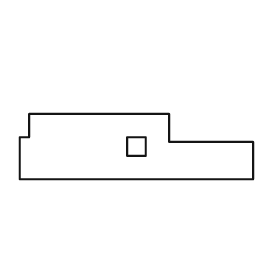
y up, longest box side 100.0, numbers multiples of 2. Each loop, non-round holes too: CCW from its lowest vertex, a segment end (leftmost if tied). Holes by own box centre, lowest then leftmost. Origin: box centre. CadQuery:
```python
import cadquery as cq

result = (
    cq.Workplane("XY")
    .moveTo(-50.0, -14.0)
    .lineTo(50.0, -14.0)
    .lineTo(50.0, 2.0)
    .lineTo(14.0, 2.0)
    .lineTo(14.0, 14.0)
    .lineTo(-46.0, 14.0)
    .lineTo(-46.0, 4.0)
    .lineTo(-50.0, 4.0)
    .close()
    .moveTo(-4.0, -4.0)
    .lineTo(4.0, -4.0)
    .lineTo(4.0, 4.0)
    .lineTo(-4.0, 4.0)
    .close()
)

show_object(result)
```